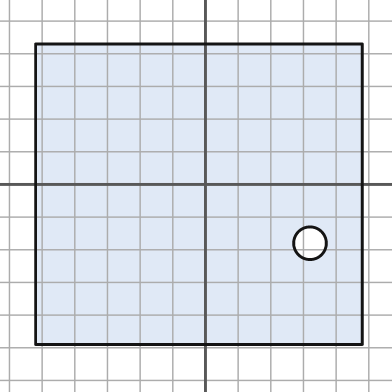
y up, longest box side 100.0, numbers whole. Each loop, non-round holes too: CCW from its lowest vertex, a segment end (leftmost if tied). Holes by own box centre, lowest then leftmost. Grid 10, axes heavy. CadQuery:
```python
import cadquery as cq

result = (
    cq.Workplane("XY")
    .moveTo(-52.0, -49.0)
    .lineTo(48.0, -49.0)
    .lineTo(48.0, 43.0)
    .lineTo(-52.0, 43.0)
    .close()
    .moveTo(32.0, -18.0)
    .circle(5.0)
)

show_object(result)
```